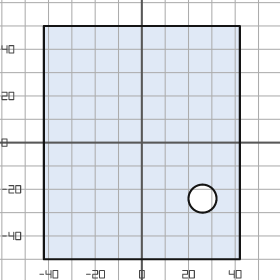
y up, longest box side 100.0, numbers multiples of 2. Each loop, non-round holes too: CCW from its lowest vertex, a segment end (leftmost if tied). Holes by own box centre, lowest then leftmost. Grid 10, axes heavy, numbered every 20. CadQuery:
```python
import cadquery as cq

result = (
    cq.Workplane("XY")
    .moveTo(-42.0, -50.0)
    .lineTo(42.0, -50.0)
    .lineTo(42.0, 50.0)
    .lineTo(-42.0, 50.0)
    .close()
    .moveTo(26.0, -24.0)
    .circle(6.0)
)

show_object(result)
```